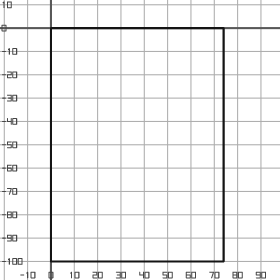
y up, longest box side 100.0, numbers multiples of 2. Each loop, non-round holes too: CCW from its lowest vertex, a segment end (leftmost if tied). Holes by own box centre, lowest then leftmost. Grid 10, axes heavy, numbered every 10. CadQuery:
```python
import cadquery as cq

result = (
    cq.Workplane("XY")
    .moveTo(0.0, -100.0)
    .lineTo(74.0, -100.0)
    .lineTo(74.0, 0.0)
    .lineTo(0.0, 0.0)
    .close()
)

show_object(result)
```